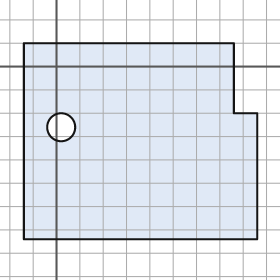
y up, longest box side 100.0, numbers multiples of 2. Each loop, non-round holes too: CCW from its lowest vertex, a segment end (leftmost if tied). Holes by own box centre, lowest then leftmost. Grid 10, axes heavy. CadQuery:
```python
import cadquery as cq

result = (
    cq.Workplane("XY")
    .moveTo(-14.0, -74.0)
    .lineTo(86.0, -74.0)
    .lineTo(86.0, -20.0)
    .lineTo(76.0, -20.0)
    .lineTo(76.0, 10.0)
    .lineTo(-14.0, 10.0)
    .close()
    .moveTo(2.0, -26.0)
    .circle(6.0)
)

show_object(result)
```